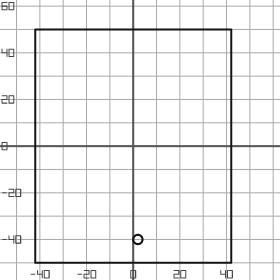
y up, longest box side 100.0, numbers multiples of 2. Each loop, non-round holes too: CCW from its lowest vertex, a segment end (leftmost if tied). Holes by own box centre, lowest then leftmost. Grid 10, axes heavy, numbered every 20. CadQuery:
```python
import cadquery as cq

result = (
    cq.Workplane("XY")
    .moveTo(-42.0, -50.0)
    .lineTo(42.0, -50.0)
    .lineTo(42.0, 50.0)
    .lineTo(-42.0, 50.0)
    .close()
    .moveTo(2.0, -40.0)
    .circle(2.0)
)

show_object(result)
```